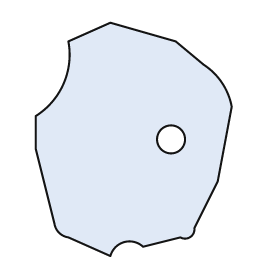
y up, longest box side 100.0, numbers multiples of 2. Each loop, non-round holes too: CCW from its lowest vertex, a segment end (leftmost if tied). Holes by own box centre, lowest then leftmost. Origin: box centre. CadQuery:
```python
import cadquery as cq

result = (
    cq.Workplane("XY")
    .moveTo(-10.0, -50.0)
    .threePointArc((-4.0, -44.0), (4.0, -46.0))
    .lineTo(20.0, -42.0)
    .threePointArc((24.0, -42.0), (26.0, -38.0))
    .lineTo(36.0, -18.0)
    .lineTo(42.0, 14.0)
    .threePointArc((38.0, 24.0), (30.0, 32.0))
    .lineTo(18.0, 42.0)
    .lineTo(-10.0, 50.0)
    .lineTo(-28.0, 42.0)
    .threePointArc((-30.0, 24.0), (-42.0, 10.0))
    .lineTo(-42.0, -4.0)
    .lineTo(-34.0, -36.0)
    .threePointArc((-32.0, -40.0), (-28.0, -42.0))
    .close()
    .moveTo(16.0, 0.0)
    .circle(6.0)
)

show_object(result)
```